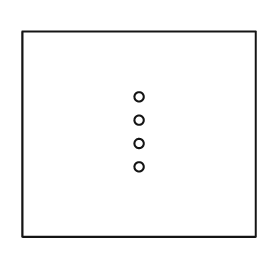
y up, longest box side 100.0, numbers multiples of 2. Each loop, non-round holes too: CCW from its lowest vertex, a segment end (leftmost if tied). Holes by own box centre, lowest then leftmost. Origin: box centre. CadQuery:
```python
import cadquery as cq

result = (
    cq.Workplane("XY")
    .moveTo(-50.0, -44.0)
    .lineTo(50.0, -44.0)
    .lineTo(50.0, 44.0)
    .lineTo(-50.0, 44.0)
    .close()
    .moveTo(0.0, -14.0)
    .circle(2.0)
    .moveTo(0.0, -4.0)
    .circle(2.0)
    .moveTo(0.0, 6.0)
    .circle(2.0)
    .moveTo(0.0, 16.0)
    .circle(2.0)
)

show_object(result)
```